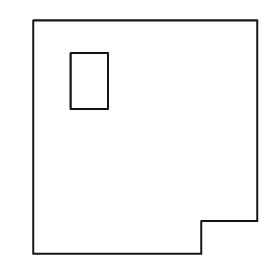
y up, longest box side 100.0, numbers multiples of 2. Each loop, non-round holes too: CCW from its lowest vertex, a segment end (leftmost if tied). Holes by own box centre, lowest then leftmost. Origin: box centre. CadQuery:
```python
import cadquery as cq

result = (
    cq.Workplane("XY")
    .moveTo(-48.0, -50.0)
    .lineTo(24.0, -50.0)
    .lineTo(24.0, -36.0)
    .lineTo(48.0, -36.0)
    .lineTo(48.0, 50.0)
    .lineTo(-48.0, 50.0)
    .close()
    .moveTo(-32.0, 12.0)
    .lineTo(-16.0, 12.0)
    .lineTo(-16.0, 36.0)
    .lineTo(-32.0, 36.0)
    .close()
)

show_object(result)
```